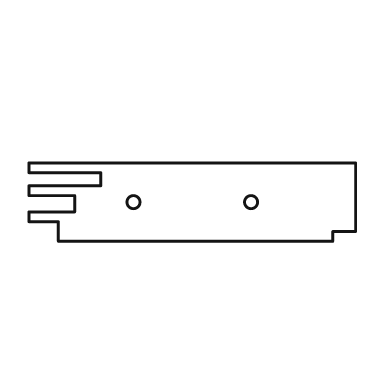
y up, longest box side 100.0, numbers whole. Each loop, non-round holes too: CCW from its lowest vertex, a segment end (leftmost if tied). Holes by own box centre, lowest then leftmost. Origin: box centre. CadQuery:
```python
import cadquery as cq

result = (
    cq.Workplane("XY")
    .moveTo(-41.0, -12.0)
    .lineTo(43.0, -12.0)
    .lineTo(43.0, -9.0)
    .lineTo(50.0, -9.0)
    .lineTo(50.0, 12.0)
    .lineTo(-50.0, 12.0)
    .lineTo(-50.0, 9.0)
    .lineTo(-28.0, 9.0)
    .lineTo(-28.0, 5.0)
    .lineTo(-50.0, 5.0)
    .lineTo(-50.0, 2.0)
    .lineTo(-36.0, 2.0)
    .lineTo(-36.0, -3.0)
    .lineTo(-50.0, -3.0)
    .lineTo(-50.0, -6.0)
    .lineTo(-41.0, -6.0)
    .close()
    .moveTo(-18.0, 0.0)
    .circle(2.0)
    .moveTo(18.0, 0.0)
    .circle(2.0)
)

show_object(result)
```